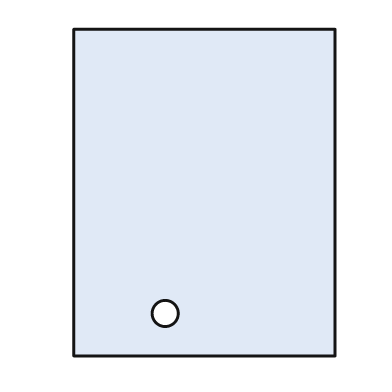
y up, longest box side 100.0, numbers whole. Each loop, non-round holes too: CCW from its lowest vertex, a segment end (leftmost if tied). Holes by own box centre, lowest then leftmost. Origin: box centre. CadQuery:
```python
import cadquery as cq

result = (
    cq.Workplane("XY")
    .moveTo(-40.0, -50.0)
    .lineTo(40.0, -50.0)
    .lineTo(40.0, 50.0)
    .lineTo(-40.0, 50.0)
    .close()
    .moveTo(-12.0, -37.0)
    .circle(4.0)
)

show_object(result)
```